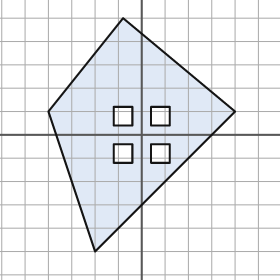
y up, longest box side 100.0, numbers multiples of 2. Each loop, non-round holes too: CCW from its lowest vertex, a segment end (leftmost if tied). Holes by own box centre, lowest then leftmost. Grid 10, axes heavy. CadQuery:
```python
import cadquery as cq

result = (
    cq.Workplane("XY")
    .moveTo(-20.0, -50.0)
    .lineTo(40.0, 10.0)
    .lineTo(-8.0, 50.0)
    .lineTo(-40.0, 10.0)
    .close()
    .moveTo(-12.0, -12.0)
    .lineTo(-4.0, -12.0)
    .lineTo(-4.0, -4.0)
    .lineTo(-12.0, -4.0)
    .close()
    .moveTo(4.0, -12.0)
    .lineTo(12.0, -12.0)
    .lineTo(12.0, -4.0)
    .lineTo(4.0, -4.0)
    .close()
    .moveTo(-12.0, 4.0)
    .lineTo(-4.0, 4.0)
    .lineTo(-4.0, 12.0)
    .lineTo(-12.0, 12.0)
    .close()
    .moveTo(4.0, 4.0)
    .lineTo(12.0, 4.0)
    .lineTo(12.0, 12.0)
    .lineTo(4.0, 12.0)
    .close()
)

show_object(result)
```